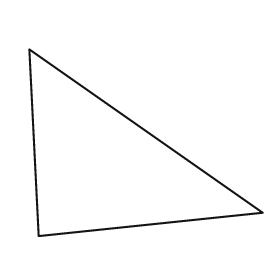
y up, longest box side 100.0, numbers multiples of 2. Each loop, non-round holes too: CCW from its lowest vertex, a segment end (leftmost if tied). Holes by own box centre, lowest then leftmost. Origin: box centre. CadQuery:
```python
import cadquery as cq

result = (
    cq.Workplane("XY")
    .moveTo(-46.0, -40.0)
    .lineTo(50.0, -30.0)
    .lineTo(-50.0, 40.0)
    .close()
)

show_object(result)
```